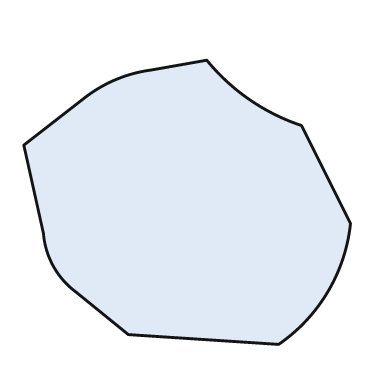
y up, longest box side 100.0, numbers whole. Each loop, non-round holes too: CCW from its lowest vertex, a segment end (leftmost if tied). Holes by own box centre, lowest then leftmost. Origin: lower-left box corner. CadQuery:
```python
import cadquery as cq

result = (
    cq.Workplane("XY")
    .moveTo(78.0, 0.0)
    .threePointArc((93.0, 16.0), (100.0, 37.0))
    .lineTo(85.0, 67.0)
    .threePointArc((69.0, 75.0), (56.0, 87.0))
    .lineTo(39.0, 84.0)
    .threePointArc((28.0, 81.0), (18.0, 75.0))
    .lineTo(0.0, 61.0)
    .lineTo(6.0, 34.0)
    .threePointArc((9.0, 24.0), (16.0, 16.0))
    .lineTo(32.0, 3.0)
    .close()
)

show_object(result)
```